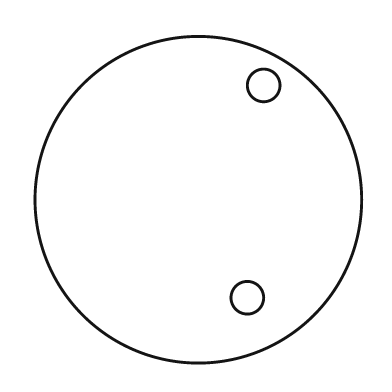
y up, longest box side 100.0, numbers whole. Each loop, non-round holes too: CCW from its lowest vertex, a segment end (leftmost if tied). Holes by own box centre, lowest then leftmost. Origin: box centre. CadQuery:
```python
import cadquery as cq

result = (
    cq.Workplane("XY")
    .moveTo(0.0, 0.0)
    .circle(50.0)
    .moveTo(15.0, -30.0)
    .circle(5.0)
    .moveTo(20.0, 35.0)
    .circle(5.0)
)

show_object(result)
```